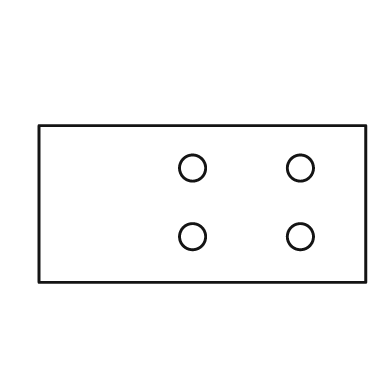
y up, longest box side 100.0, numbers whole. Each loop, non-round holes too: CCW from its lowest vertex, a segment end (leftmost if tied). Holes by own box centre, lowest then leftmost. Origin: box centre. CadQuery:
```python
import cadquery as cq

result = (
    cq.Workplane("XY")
    .moveTo(-50.0, -24.0)
    .lineTo(50.0, -24.0)
    .lineTo(50.0, 24.0)
    .lineTo(-50.0, 24.0)
    .close()
    .moveTo(-3.0, -10.0)
    .circle(4.0)
    .moveTo(30.0, -10.0)
    .circle(4.0)
    .moveTo(-3.0, 11.0)
    .circle(4.0)
    .moveTo(30.0, 11.0)
    .circle(4.0)
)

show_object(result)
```